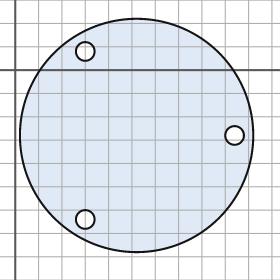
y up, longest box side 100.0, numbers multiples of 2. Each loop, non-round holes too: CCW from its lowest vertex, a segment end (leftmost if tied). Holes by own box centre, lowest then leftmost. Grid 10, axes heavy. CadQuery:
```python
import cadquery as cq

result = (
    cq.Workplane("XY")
    .moveTo(52.0, -28.0)
    .circle(50.0)
    .moveTo(30.0, -64.0)
    .circle(4.0)
    .moveTo(94.0, -28.0)
    .circle(4.0)
    .moveTo(30.0, 8.0)
    .circle(4.0)
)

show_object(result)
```